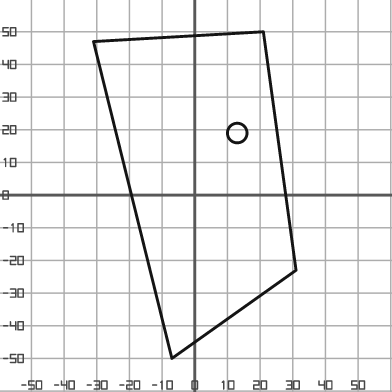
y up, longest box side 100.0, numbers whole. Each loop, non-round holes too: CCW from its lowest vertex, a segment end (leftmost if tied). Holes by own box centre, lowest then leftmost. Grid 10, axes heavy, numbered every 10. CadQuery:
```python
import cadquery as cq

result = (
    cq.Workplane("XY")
    .moveTo(-7.0, -50.0)
    .lineTo(31.0, -23.0)
    .lineTo(21.0, 50.0)
    .lineTo(-31.0, 47.0)
    .close()
    .moveTo(13.0, 19.0)
    .circle(3.0)
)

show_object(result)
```